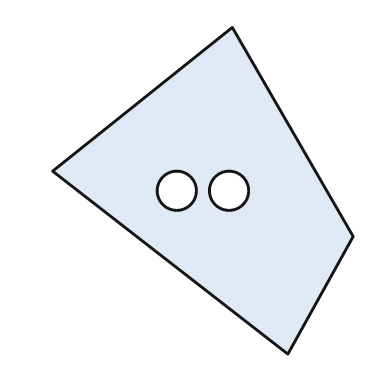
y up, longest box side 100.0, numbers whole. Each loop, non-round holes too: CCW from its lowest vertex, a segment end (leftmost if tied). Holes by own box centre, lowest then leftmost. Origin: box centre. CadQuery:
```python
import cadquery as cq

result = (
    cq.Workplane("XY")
    .moveTo(26.0, -50.0)
    .lineTo(46.0, -14.0)
    .lineTo(9.0, 50.0)
    .lineTo(-46.0, 6.0)
    .close()
    .moveTo(-8.0, 0.0)
    .circle(6.0)
    .moveTo(8.0, 0.0)
    .circle(6.0)
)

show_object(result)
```